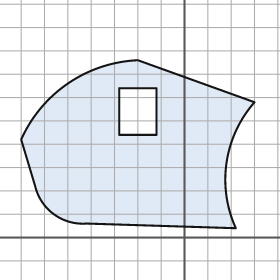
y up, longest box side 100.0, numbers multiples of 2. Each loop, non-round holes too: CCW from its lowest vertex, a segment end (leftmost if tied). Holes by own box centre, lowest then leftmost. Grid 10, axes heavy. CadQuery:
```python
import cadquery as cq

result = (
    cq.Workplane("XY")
    .moveTo(22.0, 4.0)
    .threePointArc((18.0, 32.0), (30.0, 58.0))
    .lineTo(-20.0, 76.0)
    .threePointArc((-50.0, 66.0), (-70.0, 42.0))
    .lineTo(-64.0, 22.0)
    .threePointArc((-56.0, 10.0), (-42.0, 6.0))
    .close()
    .moveTo(-28.0, 44.0)
    .lineTo(-12.0, 44.0)
    .lineTo(-12.0, 64.0)
    .lineTo(-28.0, 64.0)
    .close()
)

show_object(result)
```